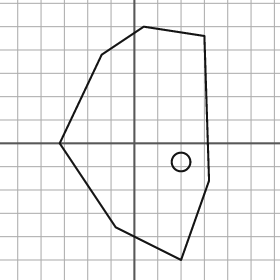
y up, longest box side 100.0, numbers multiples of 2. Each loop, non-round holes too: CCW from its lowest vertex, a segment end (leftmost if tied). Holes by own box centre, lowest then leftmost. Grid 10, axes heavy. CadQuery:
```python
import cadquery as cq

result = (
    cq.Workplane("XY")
    .moveTo(20.0, -50.0)
    .lineTo(32.0, -16.0)
    .lineTo(30.0, 46.0)
    .lineTo(4.0, 50.0)
    .lineTo(-14.0, 38.0)
    .lineTo(-32.0, 0.0)
    .lineTo(-8.0, -36.0)
    .close()
    .moveTo(20.0, -8.0)
    .circle(4.0)
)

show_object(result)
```